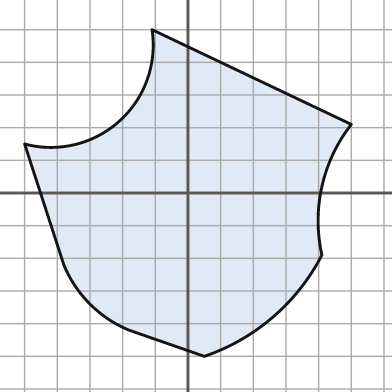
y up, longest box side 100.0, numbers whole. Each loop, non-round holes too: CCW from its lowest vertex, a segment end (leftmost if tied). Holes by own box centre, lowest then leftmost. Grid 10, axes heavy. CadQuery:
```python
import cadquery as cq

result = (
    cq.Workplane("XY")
    .moveTo(5.0, -50.0)
    .threePointArc((26.0, -38.0), (41.0, -19.0))
    .threePointArc((41.0, 2.0), (50.0, 21.0))
    .lineTo(-11.0, 50.0)
    .threePointArc((-21.0, 22.0), (-50.0, 15.0))
    .lineTo(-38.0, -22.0)
    .threePointArc((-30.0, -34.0), (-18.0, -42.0))
    .close()
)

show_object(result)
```